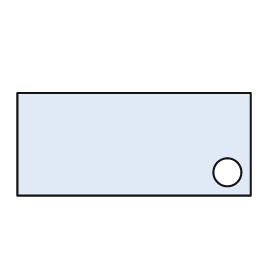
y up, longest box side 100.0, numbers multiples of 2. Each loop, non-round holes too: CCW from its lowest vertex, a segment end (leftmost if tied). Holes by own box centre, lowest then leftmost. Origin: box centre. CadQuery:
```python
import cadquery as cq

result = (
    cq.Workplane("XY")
    .moveTo(-50.0, -22.0)
    .lineTo(50.0, -22.0)
    .lineTo(50.0, 22.0)
    .lineTo(-50.0, 22.0)
    .close()
    .moveTo(40.0, -12.0)
    .circle(6.0)
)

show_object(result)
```